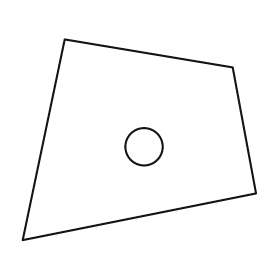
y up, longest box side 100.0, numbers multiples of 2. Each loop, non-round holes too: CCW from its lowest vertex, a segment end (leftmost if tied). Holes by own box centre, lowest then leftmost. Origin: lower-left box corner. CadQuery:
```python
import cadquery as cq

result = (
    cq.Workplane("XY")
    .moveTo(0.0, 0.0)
    .lineTo(100.0, 20.0)
    .lineTo(90.0, 74.0)
    .lineTo(18.0, 86.0)
    .close()
    .moveTo(52.0, 40.0)
    .circle(8.0)
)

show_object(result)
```